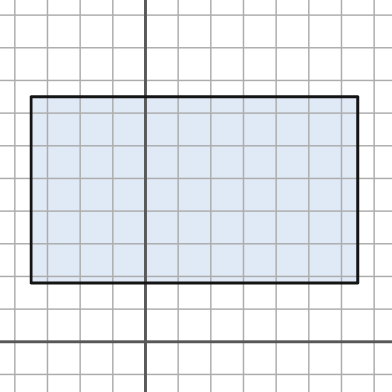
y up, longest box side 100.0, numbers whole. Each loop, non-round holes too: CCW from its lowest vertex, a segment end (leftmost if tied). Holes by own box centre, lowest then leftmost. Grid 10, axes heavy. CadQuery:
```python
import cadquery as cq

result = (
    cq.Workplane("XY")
    .moveTo(-35.0, 18.0)
    .lineTo(65.0, 18.0)
    .lineTo(65.0, 75.0)
    .lineTo(-35.0, 75.0)
    .close()
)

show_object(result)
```